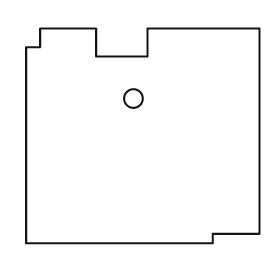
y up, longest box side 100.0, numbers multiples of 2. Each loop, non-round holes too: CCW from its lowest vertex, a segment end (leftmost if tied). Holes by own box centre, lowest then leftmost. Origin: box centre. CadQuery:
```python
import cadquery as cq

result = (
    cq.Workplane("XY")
    .moveTo(-50.0, -46.0)
    .lineTo(30.0, -46.0)
    .lineTo(30.0, -42.0)
    .lineTo(50.0, -42.0)
    .lineTo(50.0, 46.0)
    .lineTo(2.0, 46.0)
    .lineTo(2.0, 34.0)
    .lineTo(-20.0, 34.0)
    .lineTo(-20.0, 46.0)
    .lineTo(-44.0, 46.0)
    .lineTo(-44.0, 38.0)
    .lineTo(-50.0, 38.0)
    .close()
    .moveTo(-4.0, 16.0)
    .circle(4.0)
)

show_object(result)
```